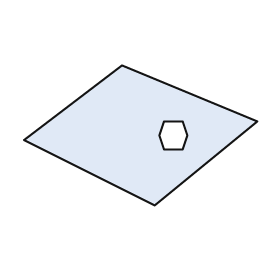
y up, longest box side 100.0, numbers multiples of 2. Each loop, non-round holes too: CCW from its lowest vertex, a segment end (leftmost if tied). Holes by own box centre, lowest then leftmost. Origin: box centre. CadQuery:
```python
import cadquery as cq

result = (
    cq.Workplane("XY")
    .moveTo(6.0, -30.0)
    .lineTo(50.0, 6.0)
    .lineTo(-8.0, 30.0)
    .lineTo(-50.0, -2.0)
    .close()
    .moveTo(10.0, -6.0)
    .lineTo(18.0, -6.0)
    .lineTo(20.0, 0.0)
    .lineTo(18.0, 6.0)
    .lineTo(10.0, 6.0)
    .lineTo(8.0, 0.0)
    .close()
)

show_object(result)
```